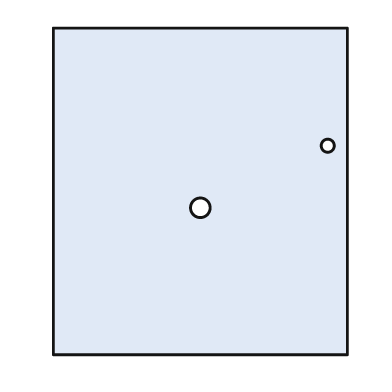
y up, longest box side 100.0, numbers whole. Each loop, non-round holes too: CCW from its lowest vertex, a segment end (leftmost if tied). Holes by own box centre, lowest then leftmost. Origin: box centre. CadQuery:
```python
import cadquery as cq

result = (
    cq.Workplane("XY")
    .moveTo(-45.0, -50.0)
    .lineTo(45.0, -50.0)
    .lineTo(45.0, 50.0)
    .lineTo(-45.0, 50.0)
    .close()
    .moveTo(0.0, -5.0)
    .circle(3.0)
    .moveTo(39.0, 14.0)
    .circle(2.0)
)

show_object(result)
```